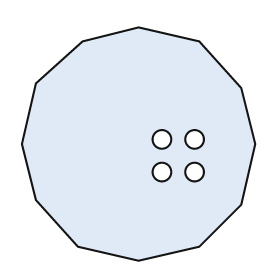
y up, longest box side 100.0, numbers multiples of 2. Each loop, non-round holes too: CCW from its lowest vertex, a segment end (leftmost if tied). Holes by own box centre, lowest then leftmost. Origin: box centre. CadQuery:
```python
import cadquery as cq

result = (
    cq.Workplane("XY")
    .moveTo(0.0, -50.0)
    .lineTo(26.0, -44.0)
    .lineTo(44.0, -26.0)
    .lineTo(50.0, 0.0)
    .lineTo(44.0, 24.0)
    .lineTo(26.0, 44.0)
    .lineTo(0.0, 50.0)
    .lineTo(-24.0, 44.0)
    .lineTo(-44.0, 26.0)
    .lineTo(-50.0, 0.0)
    .lineTo(-44.0, -24.0)
    .lineTo(-26.0, -44.0)
    .close()
    .moveTo(10.0, -12.0)
    .circle(4.0)
    .moveTo(24.0, -12.0)
    .circle(4.0)
    .moveTo(10.0, 2.0)
    .circle(4.0)
    .moveTo(24.0, 2.0)
    .circle(4.0)
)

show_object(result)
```